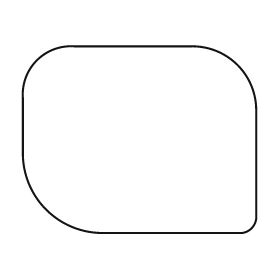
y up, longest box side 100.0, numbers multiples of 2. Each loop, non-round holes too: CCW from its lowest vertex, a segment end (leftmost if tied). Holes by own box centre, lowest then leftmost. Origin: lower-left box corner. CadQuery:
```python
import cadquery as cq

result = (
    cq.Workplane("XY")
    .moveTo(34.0, 0.0)
    .lineTo(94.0, 0.0)
    .threePointArc((98.0, 2.0), (100.0, 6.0))
    .lineTo(100.0, 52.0)
    .threePointArc((92.0, 72.0), (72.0, 80.0))
    .lineTo(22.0, 80.0)
    .threePointArc((6.0, 74.0), (0.0, 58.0))
    .lineTo(0.0, 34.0)
    .threePointArc((10.0, 10.0), (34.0, 0.0))
    .close()
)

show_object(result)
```